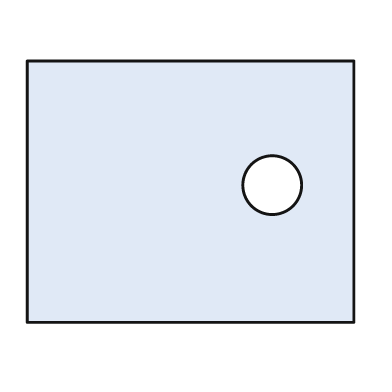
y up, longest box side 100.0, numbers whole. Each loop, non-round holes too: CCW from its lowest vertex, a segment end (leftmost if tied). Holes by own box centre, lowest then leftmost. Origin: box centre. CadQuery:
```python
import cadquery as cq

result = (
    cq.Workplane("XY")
    .moveTo(-50.0, -40.0)
    .lineTo(50.0, -40.0)
    .lineTo(50.0, 40.0)
    .lineTo(-50.0, 40.0)
    .close()
    .moveTo(25.0, 2.0)
    .circle(9.0)
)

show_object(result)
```